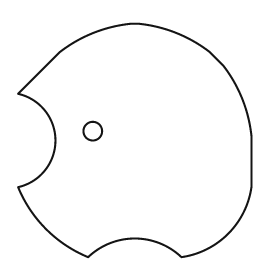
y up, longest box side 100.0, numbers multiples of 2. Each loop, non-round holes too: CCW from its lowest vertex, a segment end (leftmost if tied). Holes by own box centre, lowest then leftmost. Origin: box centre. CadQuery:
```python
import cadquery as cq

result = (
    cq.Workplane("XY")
    .moveTo(-20.0, -50.0)
    .threePointArc((0.0, -42.0), (20.0, -50.0))
    .threePointArc((40.0, -40.0), (50.0, -20.0))
    .lineTo(50.0, 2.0)
    .threePointArc((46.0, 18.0), (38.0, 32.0))
    .lineTo(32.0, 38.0)
    .threePointArc((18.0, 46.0), (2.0, 50.0))
    .lineTo(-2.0, 50.0)
    .threePointArc((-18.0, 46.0), (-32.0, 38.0))
    .lineTo(-50.0, 20.0)
    .threePointArc((-34.0, 0.0), (-50.0, -20.0))
    .threePointArc((-38.0, -38.0), (-20.0, -50.0))
    .close()
    .moveTo(-18.0, 4.0)
    .circle(4.0)
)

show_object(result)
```